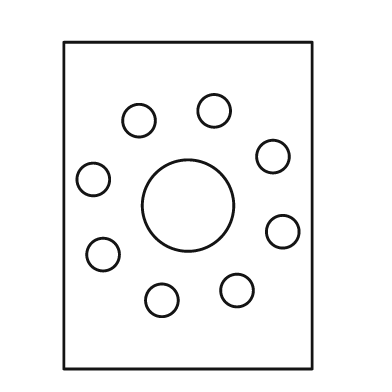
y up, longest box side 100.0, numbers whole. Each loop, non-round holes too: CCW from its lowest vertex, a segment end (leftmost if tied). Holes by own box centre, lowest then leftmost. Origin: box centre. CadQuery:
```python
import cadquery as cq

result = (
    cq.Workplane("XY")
    .moveTo(-38.0, -50.0)
    .lineTo(38.0, -50.0)
    .lineTo(38.0, 50.0)
    .lineTo(-38.0, 50.0)
    .close()
    .moveTo(-8.0, -29.0)
    .circle(5.0)
    .moveTo(15.0, -26.0)
    .circle(5.0)
    .moveTo(-26.0, -15.0)
    .circle(5.0)
    .moveTo(29.0, -8.0)
    .circle(5.0)
    .moveTo(0.0, 0.0)
    .circle(14.0)
    .moveTo(-29.0, 8.0)
    .circle(5.0)
    .moveTo(26.0, 15.0)
    .circle(5.0)
    .moveTo(-15.0, 26.0)
    .circle(5.0)
    .moveTo(8.0, 29.0)
    .circle(5.0)
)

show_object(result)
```